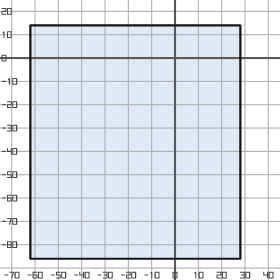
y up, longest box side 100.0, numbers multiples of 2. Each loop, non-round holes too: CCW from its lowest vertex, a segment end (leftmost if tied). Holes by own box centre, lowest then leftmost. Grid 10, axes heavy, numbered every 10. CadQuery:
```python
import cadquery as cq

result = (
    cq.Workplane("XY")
    .moveTo(-62.0, -86.0)
    .lineTo(28.0, -86.0)
    .lineTo(28.0, 14.0)
    .lineTo(-62.0, 14.0)
    .close()
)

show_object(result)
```